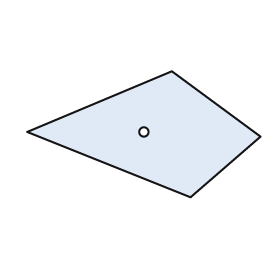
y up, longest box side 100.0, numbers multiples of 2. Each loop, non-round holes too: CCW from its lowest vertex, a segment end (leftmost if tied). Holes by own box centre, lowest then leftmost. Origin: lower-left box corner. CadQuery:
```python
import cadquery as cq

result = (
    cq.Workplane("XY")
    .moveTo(70.0, 0.0)
    .lineTo(100.0, 26.0)
    .lineTo(62.0, 54.0)
    .lineTo(0.0, 28.0)
    .close()
    .moveTo(50.0, 28.0)
    .circle(2.0)
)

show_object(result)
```